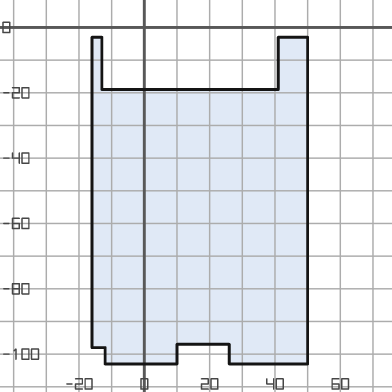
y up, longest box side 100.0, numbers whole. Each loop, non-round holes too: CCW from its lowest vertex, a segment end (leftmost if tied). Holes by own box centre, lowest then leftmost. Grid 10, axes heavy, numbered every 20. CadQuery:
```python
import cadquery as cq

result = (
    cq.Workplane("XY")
    .moveTo(-12.0, -103.0)
    .lineTo(10.0, -103.0)
    .lineTo(10.0, -97.0)
    .lineTo(26.0, -97.0)
    .lineTo(26.0, -103.0)
    .lineTo(50.0, -103.0)
    .lineTo(50.0, -3.0)
    .lineTo(41.0, -3.0)
    .lineTo(41.0, -19.0)
    .lineTo(-13.0, -19.0)
    .lineTo(-13.0, -3.0)
    .lineTo(-16.0, -3.0)
    .lineTo(-16.0, -98.0)
    .lineTo(-12.0, -98.0)
    .close()
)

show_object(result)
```